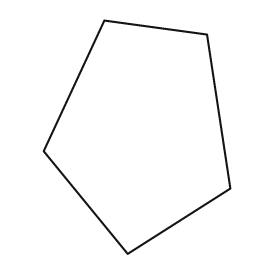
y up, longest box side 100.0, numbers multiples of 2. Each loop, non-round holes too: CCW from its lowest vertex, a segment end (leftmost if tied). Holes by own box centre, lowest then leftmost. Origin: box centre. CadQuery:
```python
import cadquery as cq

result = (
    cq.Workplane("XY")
    .moveTo(-4.0, -50.0)
    .lineTo(40.0, -22.0)
    .lineTo(30.0, 44.0)
    .lineTo(-14.0, 50.0)
    .lineTo(-40.0, -6.0)
    .close()
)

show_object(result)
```